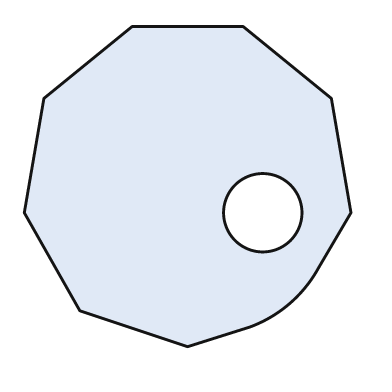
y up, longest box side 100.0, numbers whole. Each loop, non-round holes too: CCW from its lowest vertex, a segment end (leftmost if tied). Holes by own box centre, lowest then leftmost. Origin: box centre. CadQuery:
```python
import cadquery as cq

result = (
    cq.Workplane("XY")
    .moveTo(0.0, -49.0)
    .lineTo(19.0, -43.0)
    .threePointArc((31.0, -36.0), (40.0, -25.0))
    .lineTo(50.0, -8.0)
    .lineTo(44.0, 27.0)
    .lineTo(17.0, 49.0)
    .lineTo(-17.0, 49.0)
    .lineTo(-44.0, 27.0)
    .lineTo(-50.0, -8.0)
    .lineTo(-33.0, -38.0)
    .close()
    .moveTo(23.0, -8.0)
    .circle(12.0)
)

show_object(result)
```